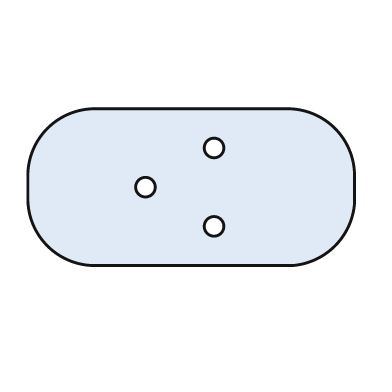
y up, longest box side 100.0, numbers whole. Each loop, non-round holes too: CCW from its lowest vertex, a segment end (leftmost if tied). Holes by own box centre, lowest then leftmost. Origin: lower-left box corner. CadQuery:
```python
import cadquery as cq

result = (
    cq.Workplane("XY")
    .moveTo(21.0, 0.0)
    .lineTo(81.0, 0.0)
    .threePointArc((94.0, 6.0), (100.0, 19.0))
    .lineTo(100.0, 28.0)
    .threePointArc((94.0, 42.0), (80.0, 48.0))
    .lineTo(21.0, 48.0)
    .threePointArc((6.0, 42.0), (0.0, 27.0))
    .lineTo(0.0, 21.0)
    .threePointArc((6.0, 6.0), (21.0, 0.0))
    .close()
    .moveTo(57.0, 12.0)
    .circle(3.0)
    .moveTo(36.0, 24.0)
    .circle(3.0)
    .moveTo(57.0, 36.0)
    .circle(3.0)
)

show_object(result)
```